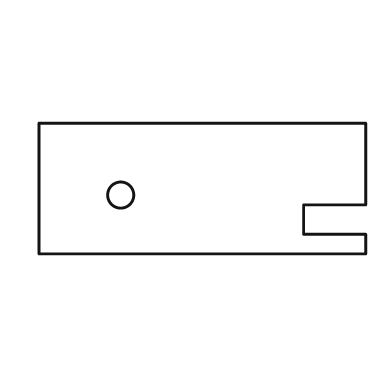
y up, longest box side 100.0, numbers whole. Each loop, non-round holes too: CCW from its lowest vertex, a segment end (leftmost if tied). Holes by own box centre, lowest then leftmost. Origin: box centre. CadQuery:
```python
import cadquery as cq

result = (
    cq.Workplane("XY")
    .moveTo(-50.0, -20.0)
    .lineTo(50.0, -20.0)
    .lineTo(50.0, -14.0)
    .lineTo(31.0, -14.0)
    .lineTo(31.0, -5.0)
    .lineTo(50.0, -5.0)
    .lineTo(50.0, 20.0)
    .lineTo(-50.0, 20.0)
    .close()
    .moveTo(-25.0, -2.0)
    .circle(4.0)
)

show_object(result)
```